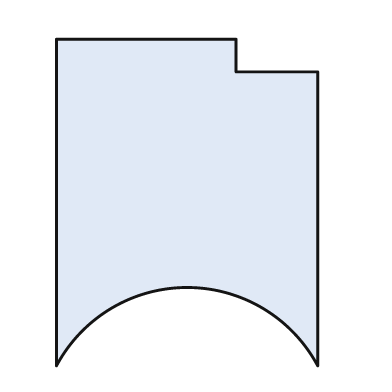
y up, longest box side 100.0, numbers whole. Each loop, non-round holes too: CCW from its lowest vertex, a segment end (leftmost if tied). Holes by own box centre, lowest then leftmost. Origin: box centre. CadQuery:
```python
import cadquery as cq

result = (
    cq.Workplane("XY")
    .moveTo(-40.0, -50.0)
    .threePointArc((0.0, -26.0), (40.0, -50.0))
    .lineTo(40.0, 40.0)
    .lineTo(15.0, 40.0)
    .lineTo(15.0, 50.0)
    .lineTo(-40.0, 50.0)
    .close()
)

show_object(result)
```